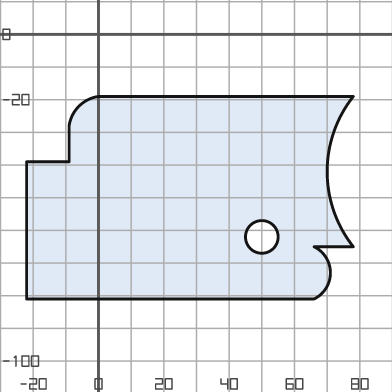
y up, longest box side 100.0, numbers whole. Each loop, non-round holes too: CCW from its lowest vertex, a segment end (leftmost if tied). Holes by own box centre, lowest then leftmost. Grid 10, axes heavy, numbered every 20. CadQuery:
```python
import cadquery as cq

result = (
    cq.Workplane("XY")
    .moveTo(-22.0, -81.0)
    .lineTo(66.0, -81.0)
    .threePointArc((71.0, -73.0), (66.0, -65.0))
    .lineTo(78.0, -65.0)
    .threePointArc((70.0, -42.0), (78.0, -19.0))
    .lineTo(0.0, -19.0)
    .threePointArc((-6.0, -22.0), (-9.0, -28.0))
    .lineTo(-9.0, -39.0)
    .lineTo(-22.0, -39.0)
    .close()
    .moveTo(50.0, -62.0)
    .circle(5.0)
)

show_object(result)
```